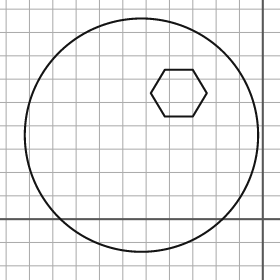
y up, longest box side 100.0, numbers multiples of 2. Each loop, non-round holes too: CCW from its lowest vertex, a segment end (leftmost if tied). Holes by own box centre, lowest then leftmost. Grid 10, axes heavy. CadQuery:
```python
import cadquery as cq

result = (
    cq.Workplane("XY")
    .moveTo(-52.0, 36.0)
    .circle(50.0)
    .moveTo(-42.0, 44.0)
    .lineTo(-30.0, 44.0)
    .lineTo(-24.0, 54.0)
    .lineTo(-30.0, 64.0)
    .lineTo(-42.0, 64.0)
    .lineTo(-48.0, 54.0)
    .close()
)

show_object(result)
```